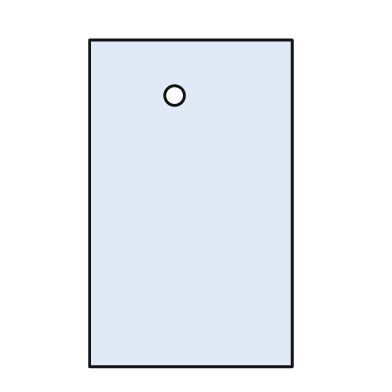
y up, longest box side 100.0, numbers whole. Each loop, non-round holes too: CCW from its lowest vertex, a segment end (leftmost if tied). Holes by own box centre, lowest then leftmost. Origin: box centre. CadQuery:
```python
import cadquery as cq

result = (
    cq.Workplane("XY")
    .moveTo(-31.0, -50.0)
    .lineTo(31.0, -50.0)
    .lineTo(31.0, 50.0)
    .lineTo(-31.0, 50.0)
    .close()
    .moveTo(-5.0, 33.0)
    .circle(3.0)
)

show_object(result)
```